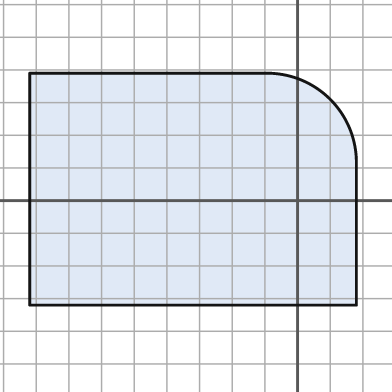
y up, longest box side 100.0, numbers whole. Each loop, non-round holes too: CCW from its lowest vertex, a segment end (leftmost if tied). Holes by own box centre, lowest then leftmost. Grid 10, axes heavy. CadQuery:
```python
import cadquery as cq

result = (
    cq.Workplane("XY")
    .moveTo(-82.0, -32.0)
    .lineTo(18.0, -32.0)
    .lineTo(18.0, 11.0)
    .threePointArc((10.0, 31.0), (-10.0, 39.0))
    .lineTo(-82.0, 39.0)
    .close()
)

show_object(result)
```